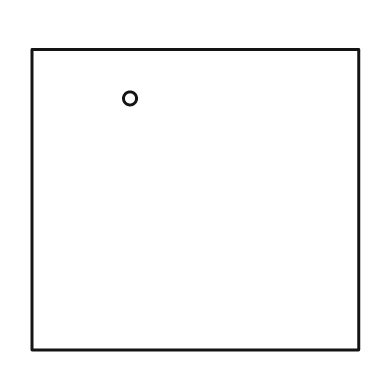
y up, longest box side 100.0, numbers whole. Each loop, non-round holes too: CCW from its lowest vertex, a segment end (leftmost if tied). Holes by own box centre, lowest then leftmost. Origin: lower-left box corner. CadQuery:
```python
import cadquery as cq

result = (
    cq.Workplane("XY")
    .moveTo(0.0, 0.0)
    .lineTo(100.0, 0.0)
    .lineTo(100.0, 92.0)
    .lineTo(0.0, 92.0)
    .close()
    .moveTo(30.0, 77.0)
    .circle(2.0)
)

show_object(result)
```